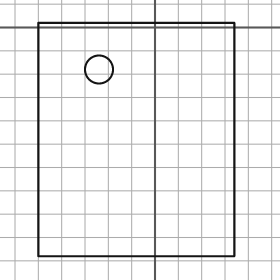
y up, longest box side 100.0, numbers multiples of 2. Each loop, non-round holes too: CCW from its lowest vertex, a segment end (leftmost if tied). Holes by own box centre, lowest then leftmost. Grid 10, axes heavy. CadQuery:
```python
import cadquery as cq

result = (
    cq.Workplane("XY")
    .moveTo(-50.0, -98.0)
    .lineTo(34.0, -98.0)
    .lineTo(34.0, 2.0)
    .lineTo(-50.0, 2.0)
    .close()
    .moveTo(-24.0, -18.0)
    .circle(6.0)
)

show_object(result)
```